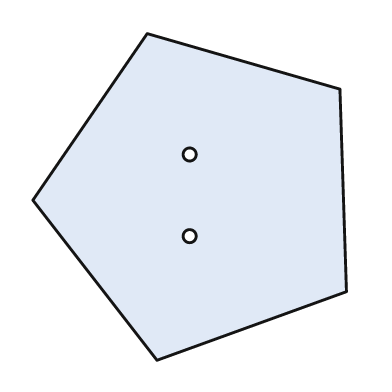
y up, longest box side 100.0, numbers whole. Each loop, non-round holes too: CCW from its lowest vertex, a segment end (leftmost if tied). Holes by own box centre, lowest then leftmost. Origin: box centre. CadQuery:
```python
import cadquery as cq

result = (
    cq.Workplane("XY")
    .moveTo(-10.0, -50.0)
    .lineTo(48.0, -29.0)
    .lineTo(46.0, 33.0)
    .lineTo(-13.0, 50.0)
    .lineTo(-48.0, -1.0)
    .close()
    .moveTo(0.0, -12.0)
    .circle(2.0)
    .moveTo(0.0, 13.0)
    .circle(2.0)
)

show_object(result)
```